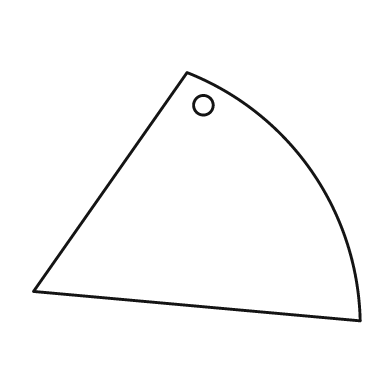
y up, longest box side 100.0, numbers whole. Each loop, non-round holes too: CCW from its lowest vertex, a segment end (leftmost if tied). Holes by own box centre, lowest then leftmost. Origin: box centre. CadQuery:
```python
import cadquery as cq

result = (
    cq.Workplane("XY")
    .moveTo(50.0, -38.0)
    .threePointArc((35.0, 8.0), (-3.0, 38.0))
    .lineTo(-50.0, -29.0)
    .close()
    .moveTo(2.0, 28.0)
    .circle(3.0)
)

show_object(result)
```